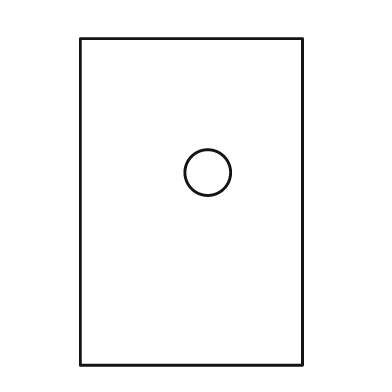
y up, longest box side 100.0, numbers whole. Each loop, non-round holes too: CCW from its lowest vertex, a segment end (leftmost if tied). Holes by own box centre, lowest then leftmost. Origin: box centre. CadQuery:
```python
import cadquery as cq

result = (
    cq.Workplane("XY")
    .moveTo(-34.0, -50.0)
    .lineTo(34.0, -50.0)
    .lineTo(34.0, 50.0)
    .lineTo(-34.0, 50.0)
    .close()
    .moveTo(5.0, 9.0)
    .circle(7.0)
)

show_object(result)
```